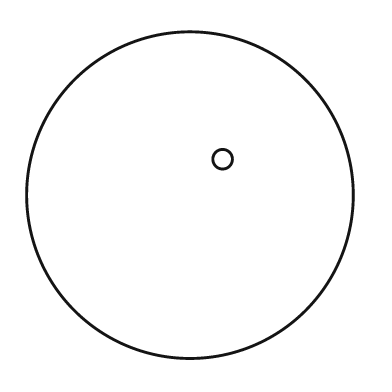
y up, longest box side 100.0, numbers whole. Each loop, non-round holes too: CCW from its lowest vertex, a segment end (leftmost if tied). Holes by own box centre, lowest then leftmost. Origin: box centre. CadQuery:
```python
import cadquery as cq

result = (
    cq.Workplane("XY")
    .moveTo(0.0, 0.0)
    .circle(50.0)
    .moveTo(10.0, 11.0)
    .circle(3.0)
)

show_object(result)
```